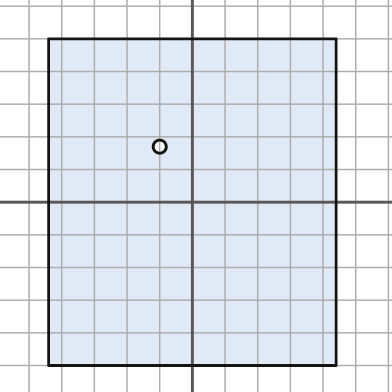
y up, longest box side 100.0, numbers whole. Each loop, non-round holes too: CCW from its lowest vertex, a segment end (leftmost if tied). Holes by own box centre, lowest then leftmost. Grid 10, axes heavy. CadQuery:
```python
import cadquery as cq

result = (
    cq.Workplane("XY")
    .moveTo(-44.0, -50.0)
    .lineTo(44.0, -50.0)
    .lineTo(44.0, 50.0)
    .lineTo(-44.0, 50.0)
    .close()
    .moveTo(-10.0, 17.0)
    .circle(2.0)
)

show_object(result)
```